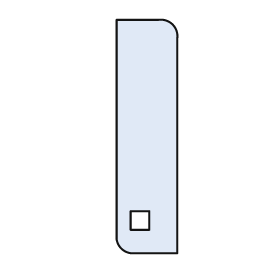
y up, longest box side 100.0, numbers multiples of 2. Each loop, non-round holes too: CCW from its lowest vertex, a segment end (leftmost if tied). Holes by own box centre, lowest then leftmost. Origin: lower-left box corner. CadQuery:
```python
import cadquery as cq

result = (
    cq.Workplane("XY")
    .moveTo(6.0, 0.0)
    .lineTo(26.0, 0.0)
    .lineTo(26.0, 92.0)
    .threePointArc((24.0, 98.0), (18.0, 100.0))
    .lineTo(0.0, 100.0)
    .lineTo(0.0, 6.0)
    .threePointArc((2.0, 2.0), (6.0, 0.0))
    .close()
    .moveTo(6.0, 10.0)
    .lineTo(14.0, 10.0)
    .lineTo(14.0, 18.0)
    .lineTo(6.0, 18.0)
    .close()
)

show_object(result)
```